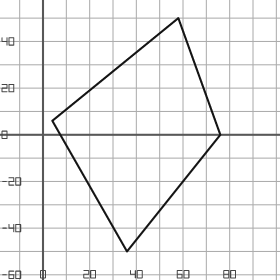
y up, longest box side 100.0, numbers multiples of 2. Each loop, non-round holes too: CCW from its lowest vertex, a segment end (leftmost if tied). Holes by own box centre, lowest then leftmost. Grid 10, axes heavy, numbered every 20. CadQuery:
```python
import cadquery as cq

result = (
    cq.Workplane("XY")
    .moveTo(36.0, -50.0)
    .lineTo(76.0, 0.0)
    .lineTo(58.0, 50.0)
    .lineTo(4.0, 6.0)
    .close()
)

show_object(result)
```